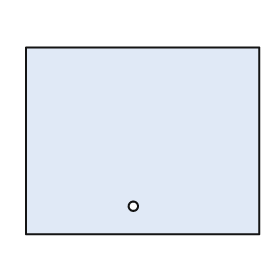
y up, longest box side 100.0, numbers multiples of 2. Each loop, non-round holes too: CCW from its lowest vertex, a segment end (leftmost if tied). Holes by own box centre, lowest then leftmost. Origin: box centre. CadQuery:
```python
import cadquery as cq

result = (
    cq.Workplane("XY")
    .moveTo(-50.0, -40.0)
    .lineTo(50.0, -40.0)
    .lineTo(50.0, 40.0)
    .lineTo(-50.0, 40.0)
    .close()
    .moveTo(-4.0, -28.0)
    .circle(2.0)
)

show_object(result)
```